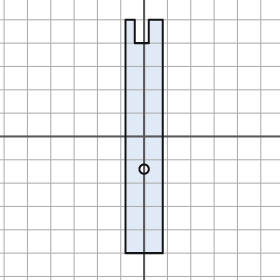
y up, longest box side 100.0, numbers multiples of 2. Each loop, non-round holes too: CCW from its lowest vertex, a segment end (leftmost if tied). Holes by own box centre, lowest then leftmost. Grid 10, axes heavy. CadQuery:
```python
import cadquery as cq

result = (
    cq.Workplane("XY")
    .moveTo(-8.0, -50.0)
    .lineTo(8.0, -50.0)
    .lineTo(8.0, 50.0)
    .lineTo(2.0, 50.0)
    .lineTo(2.0, 40.0)
    .lineTo(-4.0, 40.0)
    .lineTo(-4.0, 50.0)
    .lineTo(-8.0, 50.0)
    .close()
    .moveTo(0.0, -14.0)
    .circle(2.0)
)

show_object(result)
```